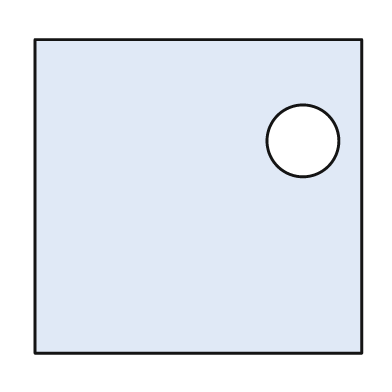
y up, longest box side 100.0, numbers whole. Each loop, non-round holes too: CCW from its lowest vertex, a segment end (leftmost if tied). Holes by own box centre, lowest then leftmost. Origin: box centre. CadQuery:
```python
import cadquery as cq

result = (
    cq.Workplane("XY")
    .moveTo(-50.0, -48.0)
    .lineTo(50.0, -48.0)
    .lineTo(50.0, 48.0)
    .lineTo(-50.0, 48.0)
    .close()
    .moveTo(32.0, 17.0)
    .circle(11.0)
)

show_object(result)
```